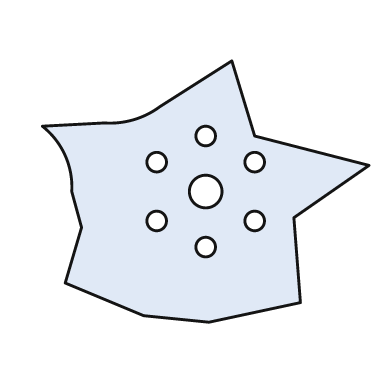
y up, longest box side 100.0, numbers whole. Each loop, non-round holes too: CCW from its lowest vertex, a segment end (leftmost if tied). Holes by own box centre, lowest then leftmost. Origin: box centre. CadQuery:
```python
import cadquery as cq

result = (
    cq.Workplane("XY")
    .moveTo(1.0, -40.0)
    .lineTo(29.0, -34.0)
    .lineTo(27.0, -8.0)
    .lineTo(50.0, 8.0)
    .lineTo(15.0, 17.0)
    .lineTo(8.0, 40.0)
    .lineTo(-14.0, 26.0)
    .threePointArc((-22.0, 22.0), (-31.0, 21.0))
    .lineTo(-50.0, 20.0)
    .threePointArc((-43.0, 11.0), (-41.0, 0.0))
    .lineTo(-38.0, -11.0)
    .lineTo(-43.0, -28.0)
    .lineTo(-19.0, -38.0)
    .close()
    .moveTo(0.0, -17.0)
    .circle(3.0)
    .moveTo(-15.0, -9.0)
    .circle(3.0)
    .moveTo(15.0, -9.0)
    .circle(3.0)
    .moveTo(0.0, 0.0)
    .circle(5.0)
    .moveTo(-15.0, 9.0)
    .circle(3.0)
    .moveTo(15.0, 9.0)
    .circle(3.0)
    .moveTo(0.0, 17.0)
    .circle(3.0)
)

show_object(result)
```